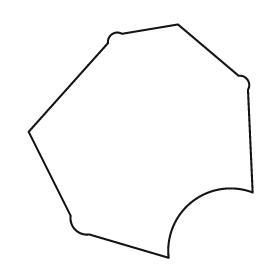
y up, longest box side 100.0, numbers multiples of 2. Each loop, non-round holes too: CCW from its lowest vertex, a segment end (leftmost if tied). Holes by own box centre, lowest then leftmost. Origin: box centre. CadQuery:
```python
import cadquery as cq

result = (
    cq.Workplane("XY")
    .moveTo(12.0, -50.0)
    .threePointArc((22.0, -26.0), (48.0, -22.0))
    .lineTo(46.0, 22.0)
    .threePointArc((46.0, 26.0), (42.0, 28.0))
    .lineTo(16.0, 50.0)
    .lineTo(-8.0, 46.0)
    .threePointArc((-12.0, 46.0), (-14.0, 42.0))
    .lineTo(-48.0, 4.0)
    .lineTo(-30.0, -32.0)
    .threePointArc((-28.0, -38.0), (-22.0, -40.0))
    .close()
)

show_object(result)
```